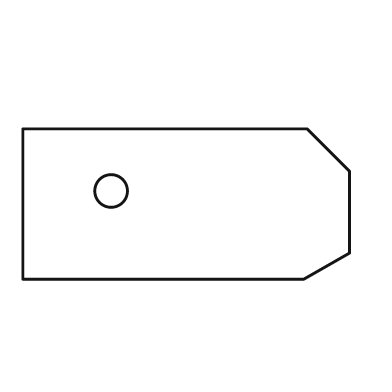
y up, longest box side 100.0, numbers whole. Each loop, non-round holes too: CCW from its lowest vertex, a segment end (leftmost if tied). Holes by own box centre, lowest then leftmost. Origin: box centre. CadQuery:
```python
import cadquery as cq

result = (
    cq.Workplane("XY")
    .moveTo(-50.0, -23.0)
    .lineTo(36.0, -23.0)
    .lineTo(50.0, -15.0)
    .lineTo(50.0, 10.0)
    .lineTo(37.0, 23.0)
    .lineTo(-50.0, 23.0)
    .close()
    .moveTo(-23.0, 4.0)
    .circle(5.0)
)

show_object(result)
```